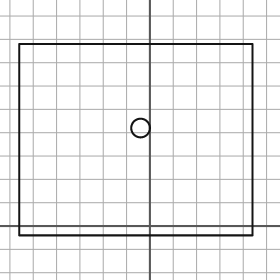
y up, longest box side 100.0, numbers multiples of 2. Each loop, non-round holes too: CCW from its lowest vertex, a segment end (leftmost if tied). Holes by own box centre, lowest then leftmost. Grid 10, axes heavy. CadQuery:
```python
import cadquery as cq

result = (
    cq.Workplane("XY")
    .moveTo(-56.0, -4.0)
    .lineTo(44.0, -4.0)
    .lineTo(44.0, 78.0)
    .lineTo(-56.0, 78.0)
    .close()
    .moveTo(-4.0, 42.0)
    .circle(4.0)
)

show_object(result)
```